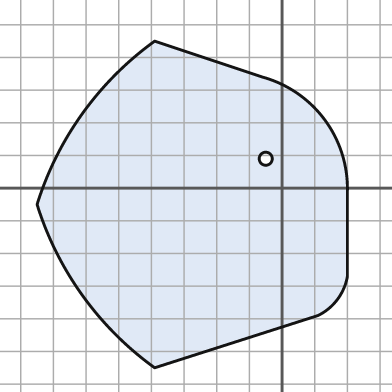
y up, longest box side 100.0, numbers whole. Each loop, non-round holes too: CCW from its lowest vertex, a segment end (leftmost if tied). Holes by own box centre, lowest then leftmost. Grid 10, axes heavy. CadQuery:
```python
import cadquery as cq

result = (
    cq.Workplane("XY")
    .moveTo(-39.0, -55.0)
    .lineTo(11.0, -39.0)
    .threePointArc((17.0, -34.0), (20.0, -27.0))
    .lineTo(20.0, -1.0)
    .threePointArc((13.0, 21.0), (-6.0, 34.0))
    .lineTo(-39.0, 45.0)
    .threePointArc((-61.0, 23.0), (-75.0, -5.0))
    .threePointArc((-61.0, -33.0), (-39.0, -55.0))
    .close()
    .moveTo(-5.0, 9.0)
    .circle(2.0)
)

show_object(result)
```